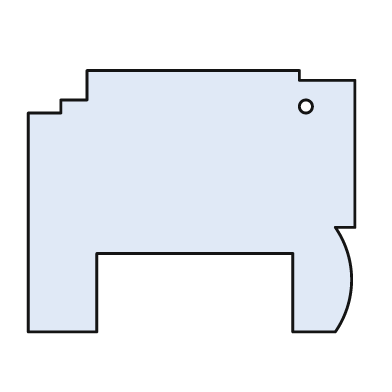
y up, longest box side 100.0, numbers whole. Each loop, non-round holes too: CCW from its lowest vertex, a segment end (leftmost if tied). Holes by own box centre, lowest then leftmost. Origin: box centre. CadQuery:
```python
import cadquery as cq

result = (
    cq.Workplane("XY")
    .moveTo(-50.0, -40.0)
    .lineTo(-29.0, -40.0)
    .lineTo(-29.0, -16.0)
    .lineTo(31.0, -16.0)
    .lineTo(31.0, -40.0)
    .lineTo(44.0, -40.0)
    .threePointArc((49.0, -24.0), (44.0, -8.0))
    .lineTo(50.0, -8.0)
    .lineTo(50.0, 37.0)
    .lineTo(33.0, 37.0)
    .lineTo(33.0, 40.0)
    .lineTo(-32.0, 40.0)
    .lineTo(-32.0, 31.0)
    .lineTo(-40.0, 31.0)
    .lineTo(-40.0, 27.0)
    .lineTo(-50.0, 27.0)
    .close()
    .moveTo(35.0, 29.0)
    .circle(2.0)
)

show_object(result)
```